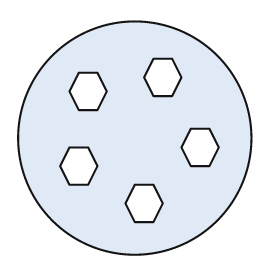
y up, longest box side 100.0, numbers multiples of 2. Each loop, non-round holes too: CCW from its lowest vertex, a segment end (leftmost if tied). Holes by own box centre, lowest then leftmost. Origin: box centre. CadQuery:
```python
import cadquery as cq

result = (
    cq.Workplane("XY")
    .moveTo(0.0, 0.0)
    .circle(50.0)
    .moveTo(0.0, -36.0)
    .lineTo(8.0, -36.0)
    .lineTo(12.0, -28.0)
    .lineTo(8.0, -20.0)
    .lineTo(0.0, -20.0)
    .lineTo(-4.0, -28.0)
    .close()
    .moveTo(-28.0, -20.0)
    .lineTo(-20.0, -20.0)
    .lineTo(-16.0, -12.0)
    .lineTo(-20.0, -4.0)
    .lineTo(-28.0, -4.0)
    .lineTo(-32.0, -12.0)
    .close()
    .moveTo(24.0, -12.0)
    .lineTo(32.0, -12.0)
    .lineTo(36.0, -4.0)
    .lineTo(32.0, 4.0)
    .lineTo(24.0, 4.0)
    .lineTo(20.0, -4.0)
    .close()
    .moveTo(-24.0, 12.0)
    .lineTo(-16.0, 12.0)
    .lineTo(-12.0, 20.0)
    .lineTo(-16.0, 28.0)
    .lineTo(-24.0, 28.0)
    .lineTo(-28.0, 20.0)
    .close()
    .moveTo(8.0, 18.0)
    .lineTo(16.0, 18.0)
    .lineTo(20.0, 26.0)
    .lineTo(16.0, 34.0)
    .lineTo(8.0, 34.0)
    .lineTo(4.0, 26.0)
    .close()
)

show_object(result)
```